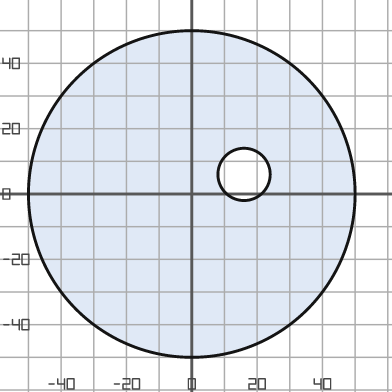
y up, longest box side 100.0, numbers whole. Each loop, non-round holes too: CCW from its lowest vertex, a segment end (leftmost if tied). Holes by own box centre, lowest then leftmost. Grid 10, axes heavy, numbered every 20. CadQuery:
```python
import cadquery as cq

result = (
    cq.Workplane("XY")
    .moveTo(0.0, 0.0)
    .circle(50.0)
    .moveTo(16.0, 6.0)
    .circle(8.0)
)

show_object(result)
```